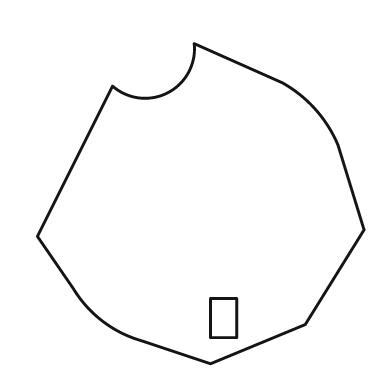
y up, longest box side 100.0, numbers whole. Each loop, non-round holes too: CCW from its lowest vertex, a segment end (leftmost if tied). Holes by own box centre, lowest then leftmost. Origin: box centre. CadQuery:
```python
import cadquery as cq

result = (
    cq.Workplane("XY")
    .moveTo(3.0, -49.0)
    .lineTo(32.0, -37.0)
    .lineTo(50.0, -8.0)
    .lineTo(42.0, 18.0)
    .threePointArc((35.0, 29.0), (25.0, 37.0))
    .lineTo(-2.0, 49.0)
    .threePointArc((-10.0, 34.0), (-27.0, 36.0))
    .lineTo(-50.0, -10.0)
    .lineTo(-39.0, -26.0)
    .threePointArc((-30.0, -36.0), (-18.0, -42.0))
    .close()
    .moveTo(3.0, -41.0)
    .lineTo(11.0, -41.0)
    .lineTo(11.0, -29.0)
    .lineTo(3.0, -29.0)
    .close()
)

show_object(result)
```